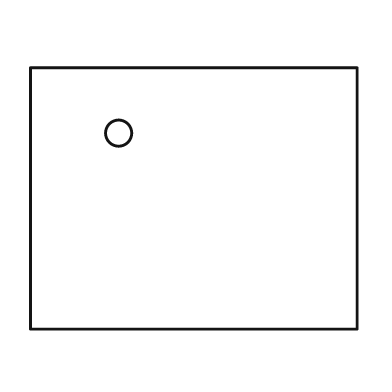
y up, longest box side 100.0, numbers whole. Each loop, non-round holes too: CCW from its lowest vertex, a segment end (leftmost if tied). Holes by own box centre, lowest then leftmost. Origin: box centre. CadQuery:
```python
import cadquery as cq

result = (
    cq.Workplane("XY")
    .moveTo(-50.0, -40.0)
    .lineTo(50.0, -40.0)
    .lineTo(50.0, 40.0)
    .lineTo(-50.0, 40.0)
    .close()
    .moveTo(-23.0, 20.0)
    .circle(4.0)
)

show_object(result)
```